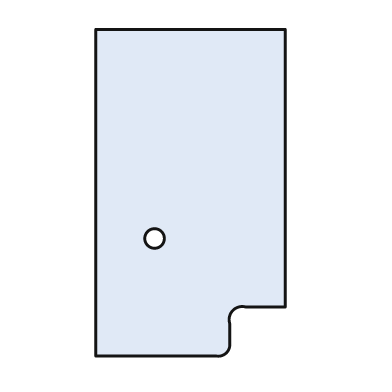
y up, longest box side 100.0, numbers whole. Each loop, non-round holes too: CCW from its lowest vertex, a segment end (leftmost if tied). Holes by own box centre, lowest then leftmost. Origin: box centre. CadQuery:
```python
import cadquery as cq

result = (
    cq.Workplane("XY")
    .moveTo(-29.0, -50.0)
    .lineTo(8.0, -50.0)
    .threePointArc((11.0, -49.0), (12.0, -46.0))
    .lineTo(12.0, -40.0)
    .threePointArc((13.0, -36.0), (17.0, -35.0))
    .lineTo(29.0, -35.0)
    .lineTo(29.0, 50.0)
    .lineTo(-29.0, 50.0)
    .close()
    .moveTo(-11.0, -14.0)
    .circle(3.0)
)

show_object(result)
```